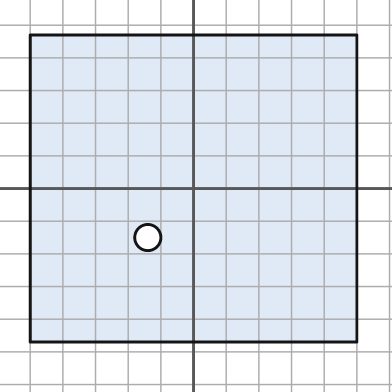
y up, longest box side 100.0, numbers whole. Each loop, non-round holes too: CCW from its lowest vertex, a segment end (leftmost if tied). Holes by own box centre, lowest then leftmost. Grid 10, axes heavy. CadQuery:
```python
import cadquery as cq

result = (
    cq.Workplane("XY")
    .moveTo(-50.0, -47.0)
    .lineTo(50.0, -47.0)
    .lineTo(50.0, 47.0)
    .lineTo(-50.0, 47.0)
    .close()
    .moveTo(-14.0, -15.0)
    .circle(4.0)
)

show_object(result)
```